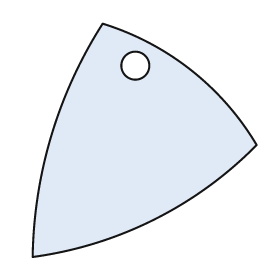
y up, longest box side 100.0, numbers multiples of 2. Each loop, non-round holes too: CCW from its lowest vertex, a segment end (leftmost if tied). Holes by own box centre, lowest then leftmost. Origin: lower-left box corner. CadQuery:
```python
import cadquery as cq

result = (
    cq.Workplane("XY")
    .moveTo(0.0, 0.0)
    .threePointArc((52.0, 16.0), (96.0, 48.0))
    .threePointArc((68.0, 80.0), (30.0, 100.0))
    .threePointArc((8.0, 52.0), (0.0, 0.0))
    .close()
    .moveTo(44.0, 82.0)
    .circle(6.0)
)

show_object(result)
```